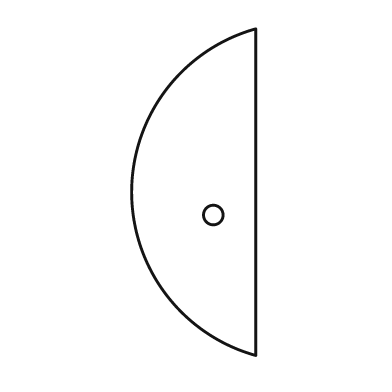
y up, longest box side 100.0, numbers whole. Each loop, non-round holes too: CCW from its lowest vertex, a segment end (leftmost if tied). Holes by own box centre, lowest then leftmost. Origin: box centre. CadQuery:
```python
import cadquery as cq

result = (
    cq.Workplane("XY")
    .moveTo(19.0, -50.0)
    .lineTo(19.0, 50.0)
    .threePointArc((-19.0, 0.0), (19.0, -50.0))
    .close()
    .moveTo(6.0, -7.0)
    .circle(3.0)
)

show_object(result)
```